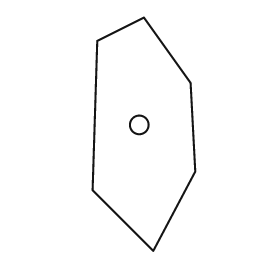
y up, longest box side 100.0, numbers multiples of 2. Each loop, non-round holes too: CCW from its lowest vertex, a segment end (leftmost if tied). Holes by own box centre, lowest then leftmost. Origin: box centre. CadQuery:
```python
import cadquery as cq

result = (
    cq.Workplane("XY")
    .moveTo(4.0, -50.0)
    .lineTo(22.0, -16.0)
    .lineTo(20.0, 22.0)
    .lineTo(0.0, 50.0)
    .lineTo(-20.0, 40.0)
    .lineTo(-22.0, -24.0)
    .close()
    .moveTo(-2.0, 4.0)
    .circle(4.0)
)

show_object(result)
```